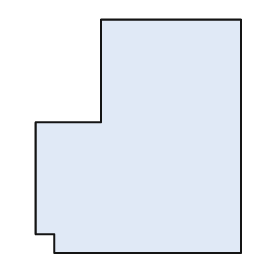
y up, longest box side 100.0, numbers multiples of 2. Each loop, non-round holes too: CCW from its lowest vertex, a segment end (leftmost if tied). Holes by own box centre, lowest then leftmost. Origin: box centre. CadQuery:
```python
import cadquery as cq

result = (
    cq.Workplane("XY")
    .moveTo(-36.0, -50.0)
    .lineTo(44.0, -50.0)
    .lineTo(44.0, 50.0)
    .lineTo(-16.0, 50.0)
    .lineTo(-16.0, 6.0)
    .lineTo(-44.0, 6.0)
    .lineTo(-44.0, -42.0)
    .lineTo(-36.0, -42.0)
    .close()
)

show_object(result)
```